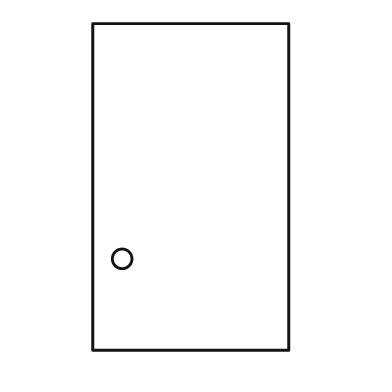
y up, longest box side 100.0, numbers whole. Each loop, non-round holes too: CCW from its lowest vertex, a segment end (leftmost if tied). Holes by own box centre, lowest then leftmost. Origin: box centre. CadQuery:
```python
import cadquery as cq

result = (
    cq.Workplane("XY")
    .moveTo(-30.0, -50.0)
    .lineTo(30.0, -50.0)
    .lineTo(30.0, 50.0)
    .lineTo(-30.0, 50.0)
    .close()
    .moveTo(-21.0, -22.0)
    .circle(3.0)
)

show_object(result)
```